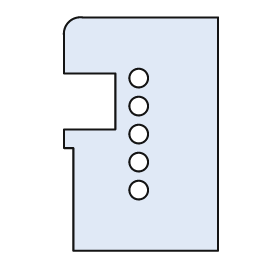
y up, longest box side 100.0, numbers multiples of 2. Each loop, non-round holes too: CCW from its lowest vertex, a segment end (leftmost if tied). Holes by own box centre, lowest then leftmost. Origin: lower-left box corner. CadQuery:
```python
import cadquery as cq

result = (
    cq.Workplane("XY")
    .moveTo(4.0, 0.0)
    .lineTo(66.0, 0.0)
    .lineTo(66.0, 100.0)
    .lineTo(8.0, 100.0)
    .threePointArc((2.0, 98.0), (0.0, 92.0))
    .lineTo(0.0, 76.0)
    .lineTo(22.0, 76.0)
    .lineTo(22.0, 52.0)
    .lineTo(0.0, 52.0)
    .lineTo(0.0, 44.0)
    .lineTo(4.0, 44.0)
    .close()
    .moveTo(32.0, 26.0)
    .circle(4.0)
    .moveTo(32.0, 38.0)
    .circle(4.0)
    .moveTo(32.0, 50.0)
    .circle(4.0)
    .moveTo(32.0, 62.0)
    .circle(4.0)
    .moveTo(32.0, 74.0)
    .circle(4.0)
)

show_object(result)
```